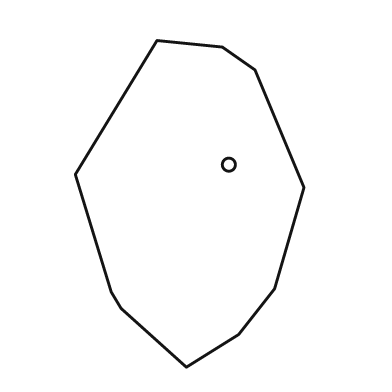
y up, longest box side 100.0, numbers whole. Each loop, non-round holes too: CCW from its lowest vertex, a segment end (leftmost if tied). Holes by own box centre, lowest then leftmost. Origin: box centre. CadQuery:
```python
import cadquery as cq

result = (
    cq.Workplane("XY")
    .moveTo(-1.0, -50.0)
    .lineTo(15.0, -40.0)
    .lineTo(26.0, -26.0)
    .lineTo(35.0, 5.0)
    .lineTo(20.0, 41.0)
    .lineTo(10.0, 48.0)
    .lineTo(-10.0, 50.0)
    .lineTo(-35.0, 9.0)
    .lineTo(-24.0, -27.0)
    .lineTo(-21.0, -32.0)
    .close()
    .moveTo(12.0, 12.0)
    .circle(2.0)
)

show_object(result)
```